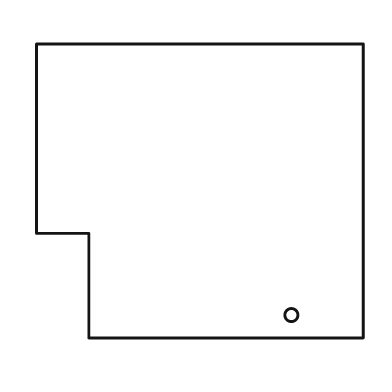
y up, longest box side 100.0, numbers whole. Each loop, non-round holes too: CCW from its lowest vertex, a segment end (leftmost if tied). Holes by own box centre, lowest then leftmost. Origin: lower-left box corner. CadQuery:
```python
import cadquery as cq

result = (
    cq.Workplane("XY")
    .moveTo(16.0, 0.0)
    .lineTo(100.0, 0.0)
    .lineTo(100.0, 90.0)
    .lineTo(0.0, 90.0)
    .lineTo(0.0, 32.0)
    .lineTo(16.0, 32.0)
    .close()
    .moveTo(78.0, 7.0)
    .circle(2.0)
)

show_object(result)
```